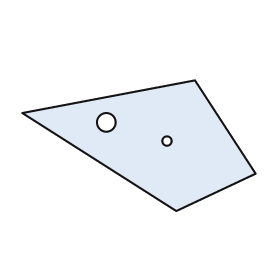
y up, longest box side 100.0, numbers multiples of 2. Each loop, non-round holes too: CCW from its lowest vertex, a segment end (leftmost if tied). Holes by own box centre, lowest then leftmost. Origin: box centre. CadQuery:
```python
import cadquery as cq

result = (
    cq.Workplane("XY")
    .moveTo(16.0, -28.0)
    .lineTo(50.0, -12.0)
    .lineTo(24.0, 28.0)
    .lineTo(-50.0, 14.0)
    .close()
    .moveTo(12.0, 2.0)
    .circle(2.0)
    .moveTo(-14.0, 10.0)
    .circle(4.0)
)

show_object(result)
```